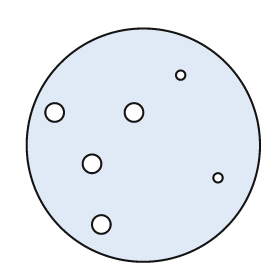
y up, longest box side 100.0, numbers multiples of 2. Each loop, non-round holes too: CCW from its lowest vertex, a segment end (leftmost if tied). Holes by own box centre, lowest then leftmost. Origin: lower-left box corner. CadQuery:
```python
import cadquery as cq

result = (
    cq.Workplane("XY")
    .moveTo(50.0, 50.0)
    .circle(50.0)
    .moveTo(32.0, 16.0)
    .circle(4.0)
    .moveTo(82.0, 36.0)
    .circle(2.0)
    .moveTo(28.0, 42.0)
    .circle(4.0)
    .moveTo(12.0, 64.0)
    .circle(4.0)
    .moveTo(46.0, 64.0)
    .circle(4.0)
    .moveTo(66.0, 80.0)
    .circle(2.0)
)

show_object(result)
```